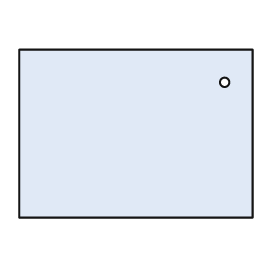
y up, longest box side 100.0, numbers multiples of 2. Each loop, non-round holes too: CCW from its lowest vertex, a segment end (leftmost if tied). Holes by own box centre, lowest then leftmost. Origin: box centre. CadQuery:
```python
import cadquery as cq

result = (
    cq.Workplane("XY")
    .moveTo(-50.0, -36.0)
    .lineTo(50.0, -36.0)
    .lineTo(50.0, 36.0)
    .lineTo(-50.0, 36.0)
    .close()
    .moveTo(38.0, 22.0)
    .circle(2.0)
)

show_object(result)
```